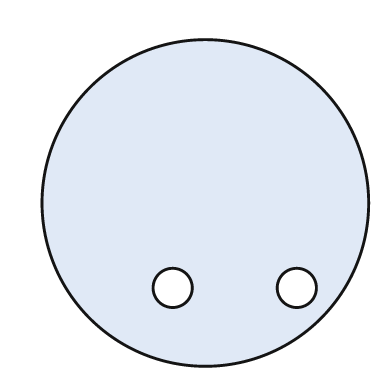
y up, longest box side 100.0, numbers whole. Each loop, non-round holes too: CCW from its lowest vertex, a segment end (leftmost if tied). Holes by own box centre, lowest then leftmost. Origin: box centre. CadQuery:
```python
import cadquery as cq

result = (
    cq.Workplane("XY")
    .moveTo(0.0, 0.0)
    .circle(50.0)
    .moveTo(-10.0, -26.0)
    .circle(6.0)
    .moveTo(28.0, -26.0)
    .circle(6.0)
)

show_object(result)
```